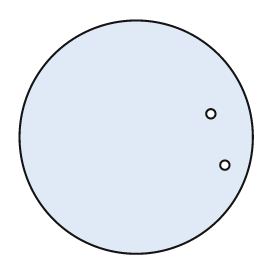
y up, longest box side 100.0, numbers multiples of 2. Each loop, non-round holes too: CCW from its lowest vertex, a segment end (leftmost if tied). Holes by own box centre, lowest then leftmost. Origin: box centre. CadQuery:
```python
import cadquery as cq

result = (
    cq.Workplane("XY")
    .moveTo(0.0, 0.0)
    .circle(50.0)
    .moveTo(38.0, -12.0)
    .circle(2.0)
    .moveTo(32.0, 10.0)
    .circle(2.0)
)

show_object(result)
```